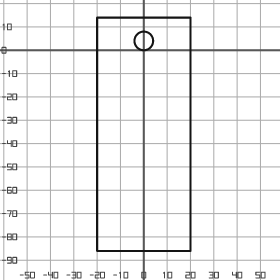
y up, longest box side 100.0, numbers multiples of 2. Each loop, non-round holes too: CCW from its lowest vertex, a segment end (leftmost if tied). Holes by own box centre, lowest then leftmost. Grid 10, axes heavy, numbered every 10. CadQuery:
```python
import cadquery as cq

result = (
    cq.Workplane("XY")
    .moveTo(-20.0, -86.0)
    .lineTo(20.0, -86.0)
    .lineTo(20.0, 14.0)
    .lineTo(-20.0, 14.0)
    .close()
    .moveTo(0.0, 4.0)
    .circle(4.0)
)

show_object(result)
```